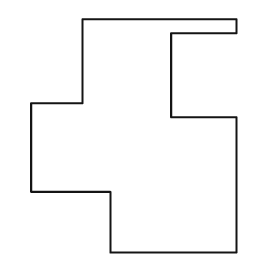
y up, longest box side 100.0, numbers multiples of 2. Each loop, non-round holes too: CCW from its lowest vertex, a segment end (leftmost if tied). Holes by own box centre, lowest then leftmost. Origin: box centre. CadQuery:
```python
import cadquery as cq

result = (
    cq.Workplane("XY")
    .moveTo(-10.0, -50.0)
    .lineTo(44.0, -50.0)
    .lineTo(44.0, 8.0)
    .lineTo(16.0, 8.0)
    .lineTo(16.0, 44.0)
    .lineTo(44.0, 44.0)
    .lineTo(44.0, 50.0)
    .lineTo(-22.0, 50.0)
    .lineTo(-22.0, 14.0)
    .lineTo(-44.0, 14.0)
    .lineTo(-44.0, -24.0)
    .lineTo(-10.0, -24.0)
    .close()
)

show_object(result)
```